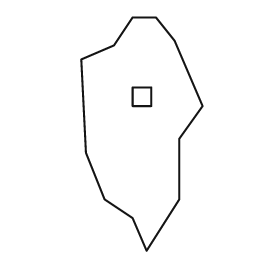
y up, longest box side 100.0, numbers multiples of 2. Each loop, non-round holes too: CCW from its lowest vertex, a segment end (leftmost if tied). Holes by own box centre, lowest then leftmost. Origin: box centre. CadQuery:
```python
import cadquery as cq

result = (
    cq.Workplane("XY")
    .moveTo(2.0, -50.0)
    .lineTo(16.0, -28.0)
    .lineTo(16.0, -2.0)
    .lineTo(26.0, 12.0)
    .lineTo(14.0, 40.0)
    .lineTo(6.0, 50.0)
    .lineTo(-4.0, 50.0)
    .lineTo(-12.0, 38.0)
    .lineTo(-26.0, 32.0)
    .lineTo(-24.0, -8.0)
    .lineTo(-16.0, -28.0)
    .lineTo(-4.0, -36.0)
    .close()
    .moveTo(-4.0, 12.0)
    .lineTo(4.0, 12.0)
    .lineTo(4.0, 20.0)
    .lineTo(-4.0, 20.0)
    .close()
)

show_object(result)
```